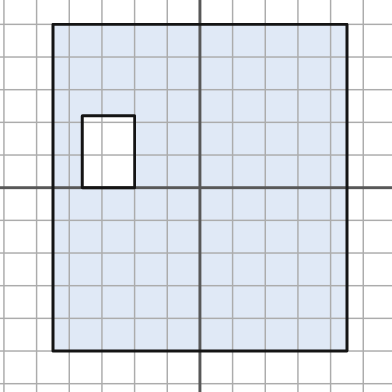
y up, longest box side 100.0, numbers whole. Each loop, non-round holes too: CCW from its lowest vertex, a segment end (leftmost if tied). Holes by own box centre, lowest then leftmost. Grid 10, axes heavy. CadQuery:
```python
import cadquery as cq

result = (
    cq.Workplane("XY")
    .moveTo(-45.0, -50.0)
    .lineTo(45.0, -50.0)
    .lineTo(45.0, 50.0)
    .lineTo(-45.0, 50.0)
    .close()
    .moveTo(-36.0, 0.0)
    .lineTo(-20.0, 0.0)
    .lineTo(-20.0, 22.0)
    .lineTo(-36.0, 22.0)
    .close()
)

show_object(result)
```